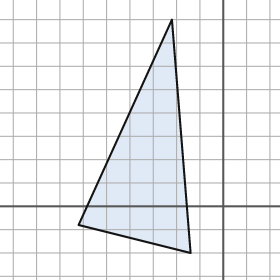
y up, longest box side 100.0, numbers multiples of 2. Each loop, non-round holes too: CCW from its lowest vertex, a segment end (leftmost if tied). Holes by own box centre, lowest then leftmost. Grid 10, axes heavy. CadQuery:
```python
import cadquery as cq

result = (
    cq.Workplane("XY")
    .moveTo(-14.0, -20.0)
    .lineTo(-22.0, 80.0)
    .lineTo(-62.0, -8.0)
    .close()
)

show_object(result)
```